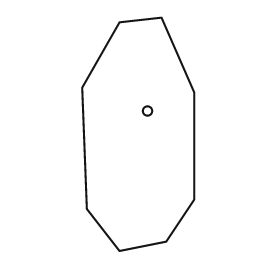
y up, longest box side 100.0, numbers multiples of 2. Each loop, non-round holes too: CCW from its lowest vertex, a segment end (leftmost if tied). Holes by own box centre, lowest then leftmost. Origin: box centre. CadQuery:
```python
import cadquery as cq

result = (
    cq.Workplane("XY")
    .moveTo(-8.0, -50.0)
    .lineTo(12.0, -46.0)
    .lineTo(24.0, -28.0)
    .lineTo(24.0, 18.0)
    .lineTo(10.0, 50.0)
    .lineTo(-8.0, 48.0)
    .lineTo(-24.0, 20.0)
    .lineTo(-22.0, -32.0)
    .close()
    .moveTo(4.0, 10.0)
    .circle(2.0)
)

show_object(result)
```